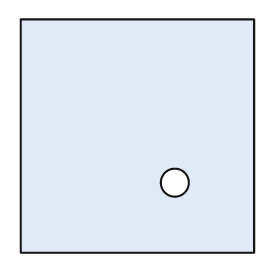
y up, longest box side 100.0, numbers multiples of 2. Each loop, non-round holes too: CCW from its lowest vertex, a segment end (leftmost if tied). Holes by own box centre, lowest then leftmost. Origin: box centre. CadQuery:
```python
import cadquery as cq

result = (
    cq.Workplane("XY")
    .moveTo(-50.0, -50.0)
    .lineTo(50.0, -50.0)
    .lineTo(50.0, 50.0)
    .lineTo(-50.0, 50.0)
    .close()
    .moveTo(16.0, -20.0)
    .circle(6.0)
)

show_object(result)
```